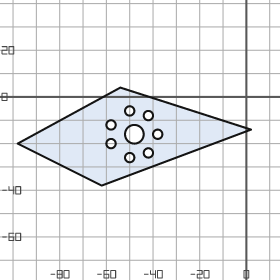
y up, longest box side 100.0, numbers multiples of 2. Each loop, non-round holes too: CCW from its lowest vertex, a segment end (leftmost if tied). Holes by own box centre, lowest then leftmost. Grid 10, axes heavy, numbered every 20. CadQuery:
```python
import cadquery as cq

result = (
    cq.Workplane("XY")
    .moveTo(-62.0, -38.0)
    .lineTo(2.0, -14.0)
    .lineTo(-54.0, 4.0)
    .lineTo(-98.0, -20.0)
    .close()
    .moveTo(-50.0, -26.0)
    .circle(2.0)
    .moveTo(-42.0, -24.0)
    .circle(2.0)
    .moveTo(-58.0, -20.0)
    .circle(2.0)
    .moveTo(-48.0, -16.0)
    .circle(4.0)
    .moveTo(-38.0, -16.0)
    .circle(2.0)
    .moveTo(-58.0, -12.0)
    .circle(2.0)
    .moveTo(-42.0, -8.0)
    .circle(2.0)
    .moveTo(-50.0, -6.0)
    .circle(2.0)
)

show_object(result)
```